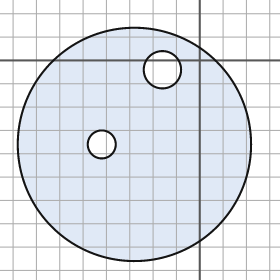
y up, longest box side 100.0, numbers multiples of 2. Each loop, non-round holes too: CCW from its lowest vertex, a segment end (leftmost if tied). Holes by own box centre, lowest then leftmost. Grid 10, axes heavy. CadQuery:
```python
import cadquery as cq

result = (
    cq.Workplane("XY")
    .moveTo(-28.0, -36.0)
    .circle(50.0)
    .moveTo(-42.0, -36.0)
    .circle(6.0)
    .moveTo(-16.0, -4.0)
    .circle(8.0)
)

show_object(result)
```